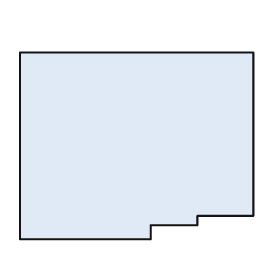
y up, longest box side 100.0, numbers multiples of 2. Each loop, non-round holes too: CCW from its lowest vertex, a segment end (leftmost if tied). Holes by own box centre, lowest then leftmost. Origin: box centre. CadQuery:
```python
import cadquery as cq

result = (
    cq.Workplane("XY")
    .moveTo(-50.0, -40.0)
    .lineTo(6.0, -40.0)
    .lineTo(6.0, -34.0)
    .lineTo(26.0, -34.0)
    .lineTo(26.0, -30.0)
    .lineTo(50.0, -30.0)
    .lineTo(50.0, 40.0)
    .lineTo(-50.0, 40.0)
    .close()
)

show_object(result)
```